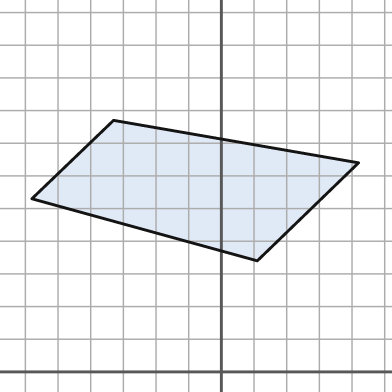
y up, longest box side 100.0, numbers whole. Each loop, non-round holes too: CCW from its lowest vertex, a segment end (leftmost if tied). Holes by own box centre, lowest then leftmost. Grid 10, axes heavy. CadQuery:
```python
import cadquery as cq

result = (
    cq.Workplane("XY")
    .moveTo(11.0, 34.0)
    .lineTo(42.0, 64.0)
    .lineTo(-33.0, 77.0)
    .lineTo(-58.0, 53.0)
    .close()
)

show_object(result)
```